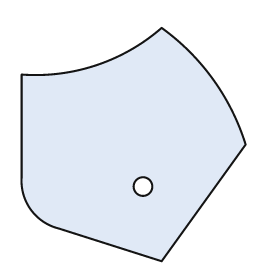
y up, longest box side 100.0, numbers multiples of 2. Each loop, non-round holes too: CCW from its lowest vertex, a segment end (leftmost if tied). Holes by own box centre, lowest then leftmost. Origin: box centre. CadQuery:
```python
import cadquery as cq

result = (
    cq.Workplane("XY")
    .moveTo(12.0, -50.0)
    .lineTo(48.0, 0.0)
    .threePointArc((34.0, 28.0), (12.0, 50.0))
    .threePointArc((-16.0, 34.0), (-48.0, 30.0))
    .lineTo(-48.0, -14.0)
    .threePointArc((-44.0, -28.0), (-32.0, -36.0))
    .close()
    .moveTo(4.0, -18.0)
    .circle(4.0)
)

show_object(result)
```